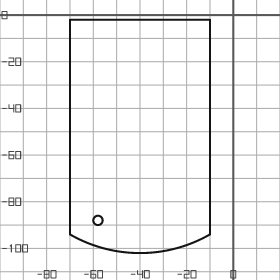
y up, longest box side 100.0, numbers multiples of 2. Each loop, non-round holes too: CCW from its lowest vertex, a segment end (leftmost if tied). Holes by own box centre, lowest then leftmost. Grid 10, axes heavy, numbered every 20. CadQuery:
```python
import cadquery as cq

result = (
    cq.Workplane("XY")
    .moveTo(-70.0, -94.0)
    .threePointArc((-40.0, -102.0), (-10.0, -94.0))
    .lineTo(-10.0, -2.0)
    .lineTo(-70.0, -2.0)
    .close()
    .moveTo(-58.0, -88.0)
    .circle(2.0)
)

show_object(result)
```